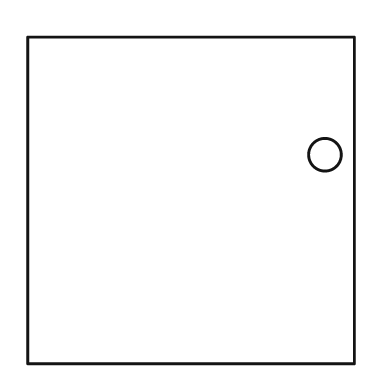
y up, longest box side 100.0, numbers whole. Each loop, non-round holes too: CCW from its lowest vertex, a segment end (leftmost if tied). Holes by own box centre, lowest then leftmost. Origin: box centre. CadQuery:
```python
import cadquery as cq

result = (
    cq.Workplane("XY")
    .moveTo(-50.0, -50.0)
    .lineTo(50.0, -50.0)
    .lineTo(50.0, 50.0)
    .lineTo(-50.0, 50.0)
    .close()
    .moveTo(41.0, 14.0)
    .circle(5.0)
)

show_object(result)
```